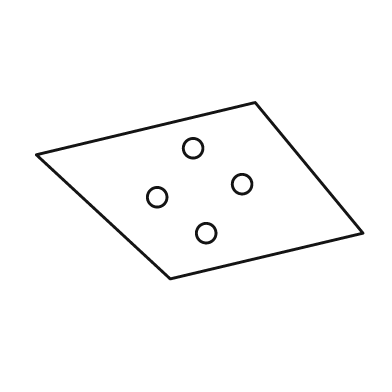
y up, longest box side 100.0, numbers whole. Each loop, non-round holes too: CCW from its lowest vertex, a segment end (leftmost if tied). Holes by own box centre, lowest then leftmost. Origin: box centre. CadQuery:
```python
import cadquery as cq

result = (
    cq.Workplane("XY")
    .moveTo(-9.0, -27.0)
    .lineTo(50.0, -13.0)
    .lineTo(17.0, 27.0)
    .lineTo(-50.0, 11.0)
    .close()
    .moveTo(2.0, -13.0)
    .circle(3.0)
    .moveTo(-13.0, -2.0)
    .circle(3.0)
    .moveTo(13.0, 2.0)
    .circle(3.0)
    .moveTo(-2.0, 13.0)
    .circle(3.0)
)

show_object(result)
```